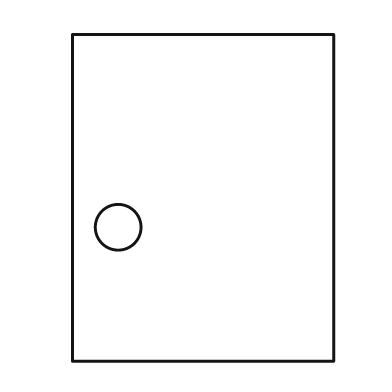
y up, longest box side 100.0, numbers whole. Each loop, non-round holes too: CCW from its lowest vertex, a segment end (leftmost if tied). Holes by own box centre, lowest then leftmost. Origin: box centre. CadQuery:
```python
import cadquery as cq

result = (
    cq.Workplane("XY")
    .moveTo(-40.0, -50.0)
    .lineTo(40.0, -50.0)
    .lineTo(40.0, 50.0)
    .lineTo(-40.0, 50.0)
    .close()
    .moveTo(-26.0, -9.0)
    .circle(7.0)
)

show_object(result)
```